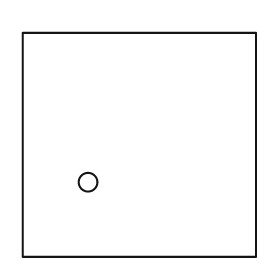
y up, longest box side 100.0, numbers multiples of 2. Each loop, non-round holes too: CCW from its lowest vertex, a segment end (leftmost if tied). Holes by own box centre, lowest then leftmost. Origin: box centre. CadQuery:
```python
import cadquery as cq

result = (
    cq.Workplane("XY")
    .moveTo(-50.0, -48.0)
    .lineTo(50.0, -48.0)
    .lineTo(50.0, 48.0)
    .lineTo(-50.0, 48.0)
    .close()
    .moveTo(-22.0, -16.0)
    .circle(4.0)
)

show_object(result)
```